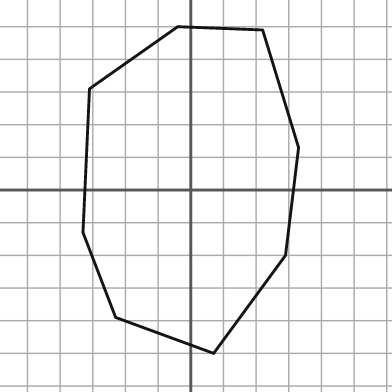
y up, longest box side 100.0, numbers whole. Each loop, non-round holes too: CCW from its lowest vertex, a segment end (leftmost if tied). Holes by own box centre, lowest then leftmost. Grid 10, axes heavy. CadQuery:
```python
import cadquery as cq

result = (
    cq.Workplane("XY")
    .moveTo(7.0, -50.0)
    .lineTo(29.0, -20.0)
    .lineTo(33.0, 13.0)
    .lineTo(22.0, 49.0)
    .lineTo(-4.0, 50.0)
    .lineTo(-31.0, 31.0)
    .lineTo(-33.0, -13.0)
    .lineTo(-23.0, -39.0)
    .close()
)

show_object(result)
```